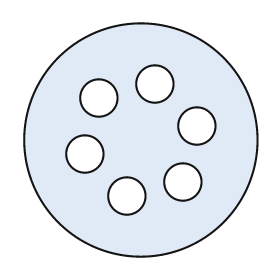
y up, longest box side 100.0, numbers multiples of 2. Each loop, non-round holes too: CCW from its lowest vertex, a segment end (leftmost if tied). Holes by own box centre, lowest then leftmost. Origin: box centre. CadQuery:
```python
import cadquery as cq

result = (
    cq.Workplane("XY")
    .moveTo(0.0, 0.0)
    .circle(50.0)
    .moveTo(-6.0, -24.0)
    .circle(8.0)
    .moveTo(18.0, -18.0)
    .circle(8.0)
    .moveTo(-24.0, -6.0)
    .circle(8.0)
    .moveTo(24.0, 6.0)
    .circle(8.0)
    .moveTo(-18.0, 18.0)
    .circle(8.0)
    .moveTo(6.0, 24.0)
    .circle(8.0)
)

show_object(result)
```